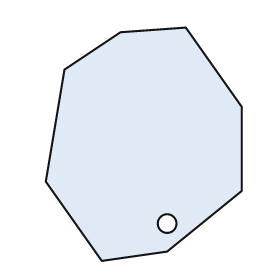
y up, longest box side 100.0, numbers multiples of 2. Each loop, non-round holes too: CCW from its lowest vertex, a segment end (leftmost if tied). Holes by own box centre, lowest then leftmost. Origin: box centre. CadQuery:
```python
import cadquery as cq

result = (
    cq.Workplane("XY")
    .moveTo(-18.0, -50.0)
    .lineTo(10.0, -46.0)
    .lineTo(42.0, -20.0)
    .lineTo(42.0, 16.0)
    .lineTo(18.0, 50.0)
    .lineTo(-10.0, 48.0)
    .lineTo(-34.0, 32.0)
    .lineTo(-42.0, -16.0)
    .close()
    .moveTo(10.0, -34.0)
    .circle(4.0)
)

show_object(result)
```